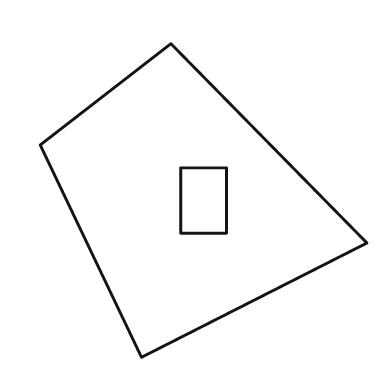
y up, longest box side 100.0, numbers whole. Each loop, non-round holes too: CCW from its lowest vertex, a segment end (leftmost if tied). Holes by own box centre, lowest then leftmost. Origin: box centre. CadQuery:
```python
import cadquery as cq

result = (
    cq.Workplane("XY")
    .moveTo(-19.0, -48.0)
    .lineTo(50.0, -13.0)
    .lineTo(-10.0, 48.0)
    .lineTo(-50.0, 17.0)
    .close()
    .moveTo(-7.0, -10.0)
    .lineTo(7.0, -10.0)
    .lineTo(7.0, 10.0)
    .lineTo(-7.0, 10.0)
    .close()
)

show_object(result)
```